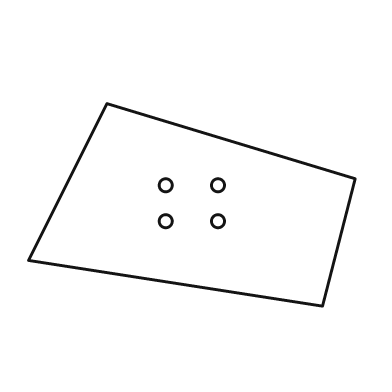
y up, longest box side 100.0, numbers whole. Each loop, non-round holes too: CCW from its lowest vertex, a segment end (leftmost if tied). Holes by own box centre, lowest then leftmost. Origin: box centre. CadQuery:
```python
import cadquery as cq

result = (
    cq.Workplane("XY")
    .moveTo(40.0, -31.0)
    .lineTo(50.0, 8.0)
    .lineTo(-26.0, 31.0)
    .lineTo(-50.0, -17.0)
    .close()
    .moveTo(-8.0, -5.0)
    .circle(2.0)
    .moveTo(8.0, -5.0)
    .circle(2.0)
    .moveTo(-8.0, 6.0)
    .circle(2.0)
    .moveTo(8.0, 6.0)
    .circle(2.0)
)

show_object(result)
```